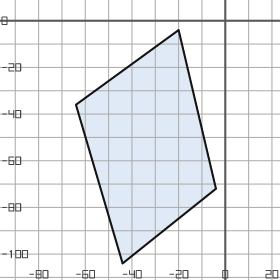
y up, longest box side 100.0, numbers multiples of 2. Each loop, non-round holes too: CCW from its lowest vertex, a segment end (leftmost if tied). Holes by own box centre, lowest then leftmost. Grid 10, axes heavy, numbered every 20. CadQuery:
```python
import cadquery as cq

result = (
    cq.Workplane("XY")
    .moveTo(-44.0, -104.0)
    .lineTo(-4.0, -72.0)
    .lineTo(-20.0, -4.0)
    .lineTo(-64.0, -36.0)
    .close()
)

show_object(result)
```